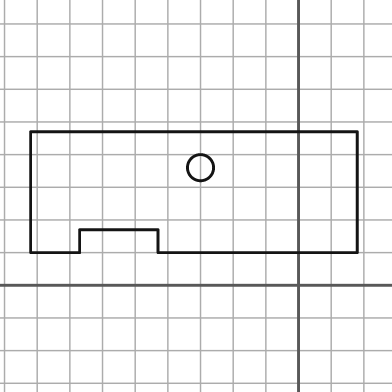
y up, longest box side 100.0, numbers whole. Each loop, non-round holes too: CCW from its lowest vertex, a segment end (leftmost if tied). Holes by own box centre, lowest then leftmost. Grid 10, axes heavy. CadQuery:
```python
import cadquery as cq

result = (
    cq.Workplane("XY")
    .moveTo(-82.0, 10.0)
    .lineTo(-67.0, 10.0)
    .lineTo(-67.0, 17.0)
    .lineTo(-43.0, 17.0)
    .lineTo(-43.0, 10.0)
    .lineTo(18.0, 10.0)
    .lineTo(18.0, 47.0)
    .lineTo(-82.0, 47.0)
    .close()
    .moveTo(-30.0, 36.0)
    .circle(4.0)
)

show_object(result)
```